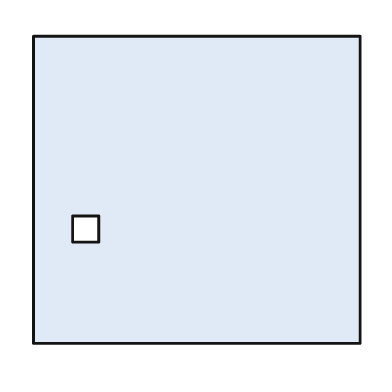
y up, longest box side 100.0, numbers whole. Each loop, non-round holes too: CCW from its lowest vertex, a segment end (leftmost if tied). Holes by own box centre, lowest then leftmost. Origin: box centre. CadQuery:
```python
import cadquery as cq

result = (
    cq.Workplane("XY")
    .moveTo(-50.0, -47.0)
    .lineTo(50.0, -47.0)
    .lineTo(50.0, 47.0)
    .lineTo(-50.0, 47.0)
    .close()
    .moveTo(-38.0, -16.0)
    .lineTo(-30.0, -16.0)
    .lineTo(-30.0, -8.0)
    .lineTo(-38.0, -8.0)
    .close()
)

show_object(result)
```